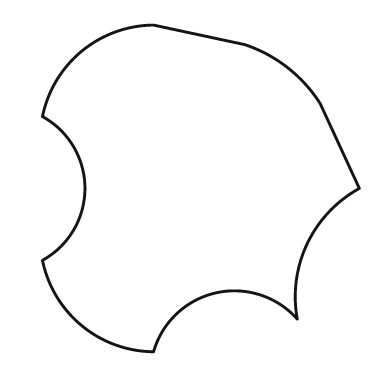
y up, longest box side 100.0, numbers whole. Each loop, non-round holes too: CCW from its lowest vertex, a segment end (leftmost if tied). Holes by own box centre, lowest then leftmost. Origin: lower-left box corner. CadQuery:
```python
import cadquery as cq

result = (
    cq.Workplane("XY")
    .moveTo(34.0, 0.0)
    .threePointArc((53.0, 18.0), (78.0, 10.0))
    .threePointArc((81.0, 33.0), (97.0, 50.0))
    .lineTo(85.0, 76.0)
    .threePointArc((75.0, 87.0), (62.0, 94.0))
    .lineTo(34.0, 100.0)
    .threePointArc((12.0, 92.0), (0.0, 72.0))
    .threePointArc((13.0, 50.0), (0.0, 28.0))
    .threePointArc((12.0, 8.0), (34.0, 0.0))
    .close()
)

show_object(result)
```